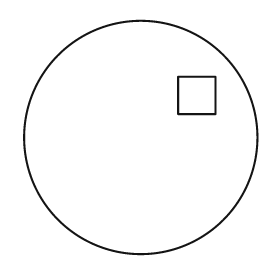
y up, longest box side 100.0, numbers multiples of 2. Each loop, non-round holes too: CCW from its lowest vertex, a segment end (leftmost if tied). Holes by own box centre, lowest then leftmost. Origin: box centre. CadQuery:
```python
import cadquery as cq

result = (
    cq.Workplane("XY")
    .moveTo(0.0, 0.0)
    .circle(50.0)
    .moveTo(16.0, 10.0)
    .lineTo(32.0, 10.0)
    .lineTo(32.0, 26.0)
    .lineTo(16.0, 26.0)
    .close()
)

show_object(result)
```